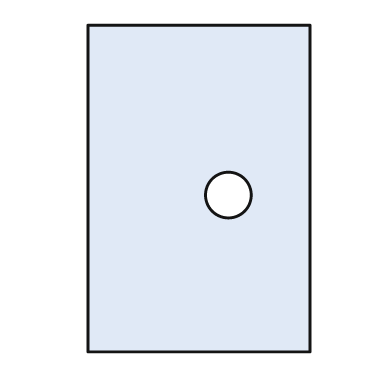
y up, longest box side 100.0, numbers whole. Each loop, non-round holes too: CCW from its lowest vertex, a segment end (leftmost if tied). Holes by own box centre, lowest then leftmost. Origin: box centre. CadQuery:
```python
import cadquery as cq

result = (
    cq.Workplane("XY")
    .moveTo(-34.0, -50.0)
    .lineTo(34.0, -50.0)
    .lineTo(34.0, 50.0)
    .lineTo(-34.0, 50.0)
    .close()
    .moveTo(9.0, -2.0)
    .circle(7.0)
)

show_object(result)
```